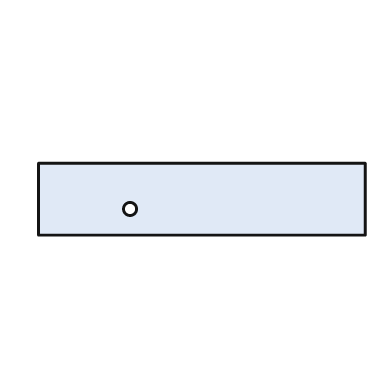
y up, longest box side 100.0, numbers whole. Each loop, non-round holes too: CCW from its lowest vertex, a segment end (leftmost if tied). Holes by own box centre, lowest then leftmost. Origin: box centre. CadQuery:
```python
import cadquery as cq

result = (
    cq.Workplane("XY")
    .moveTo(-50.0, -11.0)
    .lineTo(50.0, -11.0)
    .lineTo(50.0, 11.0)
    .lineTo(-50.0, 11.0)
    .close()
    .moveTo(-22.0, -3.0)
    .circle(2.0)
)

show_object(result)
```